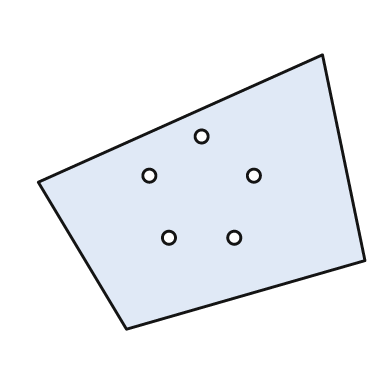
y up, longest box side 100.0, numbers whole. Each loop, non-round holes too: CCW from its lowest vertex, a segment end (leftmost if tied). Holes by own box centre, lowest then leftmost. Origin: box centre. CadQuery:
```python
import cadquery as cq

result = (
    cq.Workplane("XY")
    .moveTo(-23.0, -42.0)
    .lineTo(50.0, -21.0)
    .lineTo(37.0, 42.0)
    .lineTo(-50.0, 3.0)
    .close()
    .moveTo(-10.0, -14.0)
    .circle(2.0)
    .moveTo(10.0, -14.0)
    .circle(2.0)
    .moveTo(-16.0, 5.0)
    .circle(2.0)
    .moveTo(16.0, 5.0)
    .circle(2.0)
    .moveTo(0.0, 17.0)
    .circle(2.0)
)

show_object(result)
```